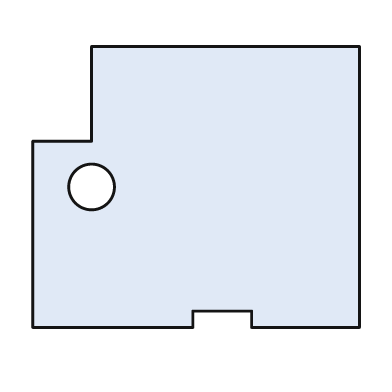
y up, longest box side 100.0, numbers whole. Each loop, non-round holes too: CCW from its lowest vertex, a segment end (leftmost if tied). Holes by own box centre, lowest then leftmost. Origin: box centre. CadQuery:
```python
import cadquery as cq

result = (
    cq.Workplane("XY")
    .moveTo(-50.0, -43.0)
    .lineTo(-1.0, -43.0)
    .lineTo(-1.0, -38.0)
    .lineTo(17.0, -38.0)
    .lineTo(17.0, -43.0)
    .lineTo(50.0, -43.0)
    .lineTo(50.0, 43.0)
    .lineTo(-32.0, 43.0)
    .lineTo(-32.0, 14.0)
    .lineTo(-50.0, 14.0)
    .close()
    .moveTo(-32.0, 0.0)
    .circle(7.0)
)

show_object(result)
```